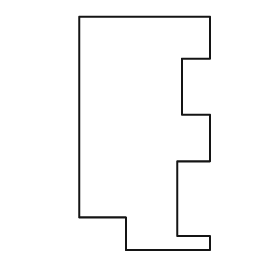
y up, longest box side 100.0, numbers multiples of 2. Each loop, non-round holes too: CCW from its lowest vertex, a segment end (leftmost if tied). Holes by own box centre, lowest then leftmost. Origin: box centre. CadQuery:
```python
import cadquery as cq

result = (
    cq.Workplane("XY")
    .moveTo(-8.0, -50.0)
    .lineTo(28.0, -50.0)
    .lineTo(28.0, -44.0)
    .lineTo(14.0, -44.0)
    .lineTo(14.0, -12.0)
    .lineTo(28.0, -12.0)
    .lineTo(28.0, 8.0)
    .lineTo(16.0, 8.0)
    .lineTo(16.0, 32.0)
    .lineTo(28.0, 32.0)
    .lineTo(28.0, 50.0)
    .lineTo(-28.0, 50.0)
    .lineTo(-28.0, -36.0)
    .lineTo(-8.0, -36.0)
    .close()
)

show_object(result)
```